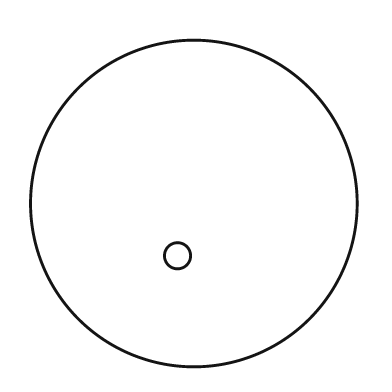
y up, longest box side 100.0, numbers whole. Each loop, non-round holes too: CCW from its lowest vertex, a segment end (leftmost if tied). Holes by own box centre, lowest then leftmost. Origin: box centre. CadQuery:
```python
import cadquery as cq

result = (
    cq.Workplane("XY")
    .moveTo(0.0, 0.0)
    .circle(50.0)
    .moveTo(-5.0, -16.0)
    .circle(4.0)
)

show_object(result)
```